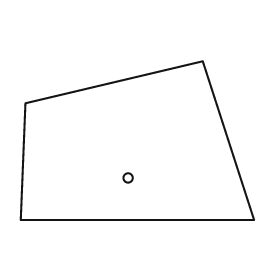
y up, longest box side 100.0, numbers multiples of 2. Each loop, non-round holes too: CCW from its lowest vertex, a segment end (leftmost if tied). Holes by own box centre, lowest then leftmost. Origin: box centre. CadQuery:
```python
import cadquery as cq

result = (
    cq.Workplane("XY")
    .moveTo(-50.0, -34.0)
    .lineTo(50.0, -34.0)
    .lineTo(28.0, 34.0)
    .lineTo(-48.0, 16.0)
    .close()
    .moveTo(-4.0, -16.0)
    .circle(2.0)
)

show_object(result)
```